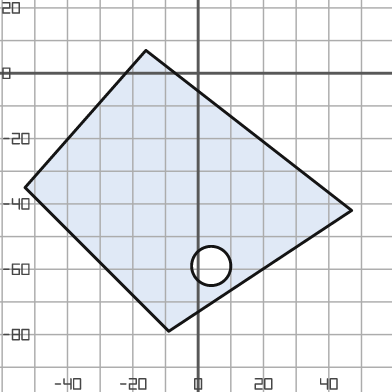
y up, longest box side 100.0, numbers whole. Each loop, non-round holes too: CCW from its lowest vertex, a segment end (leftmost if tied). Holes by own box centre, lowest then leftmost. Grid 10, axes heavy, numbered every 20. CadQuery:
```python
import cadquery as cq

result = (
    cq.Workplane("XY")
    .moveTo(-9.0, -79.0)
    .lineTo(47.0, -42.0)
    .lineTo(-16.0, 7.0)
    .lineTo(-53.0, -35.0)
    .close()
    .moveTo(4.0, -59.0)
    .circle(6.0)
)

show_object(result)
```